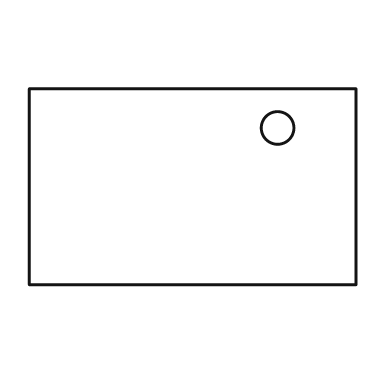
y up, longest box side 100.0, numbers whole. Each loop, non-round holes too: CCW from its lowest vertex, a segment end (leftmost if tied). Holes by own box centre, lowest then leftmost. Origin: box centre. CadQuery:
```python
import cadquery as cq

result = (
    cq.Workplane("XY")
    .moveTo(-50.0, -30.0)
    .lineTo(50.0, -30.0)
    .lineTo(50.0, 30.0)
    .lineTo(-50.0, 30.0)
    .close()
    .moveTo(26.0, 18.0)
    .circle(5.0)
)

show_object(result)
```